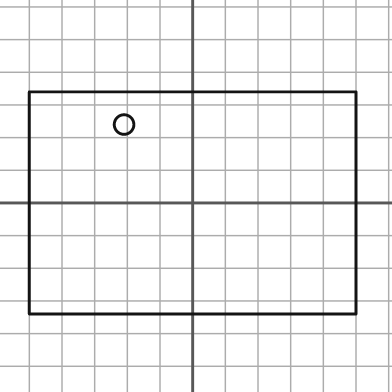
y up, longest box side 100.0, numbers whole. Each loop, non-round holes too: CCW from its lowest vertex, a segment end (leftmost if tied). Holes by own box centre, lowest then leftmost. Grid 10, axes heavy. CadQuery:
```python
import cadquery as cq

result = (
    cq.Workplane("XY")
    .moveTo(-50.0, -34.0)
    .lineTo(50.0, -34.0)
    .lineTo(50.0, 34.0)
    .lineTo(-50.0, 34.0)
    .close()
    .moveTo(-21.0, 24.0)
    .circle(3.0)
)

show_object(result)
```